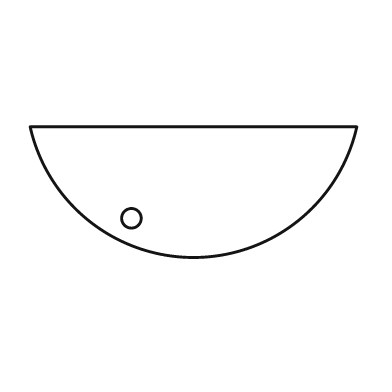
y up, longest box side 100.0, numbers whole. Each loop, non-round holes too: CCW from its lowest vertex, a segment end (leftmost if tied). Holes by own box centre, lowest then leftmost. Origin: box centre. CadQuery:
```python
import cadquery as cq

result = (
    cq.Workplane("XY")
    .moveTo(-50.0, 20.0)
    .threePointArc((0.0, -20.0), (50.0, 20.0))
    .close()
    .moveTo(-19.0, -8.0)
    .circle(3.0)
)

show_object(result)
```